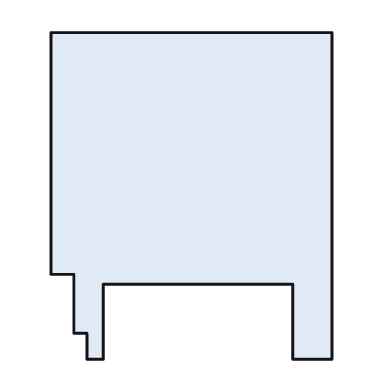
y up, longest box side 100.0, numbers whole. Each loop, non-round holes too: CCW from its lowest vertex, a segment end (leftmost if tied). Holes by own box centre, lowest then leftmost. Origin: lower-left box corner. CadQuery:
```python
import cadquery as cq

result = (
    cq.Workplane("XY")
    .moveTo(11.0, 0.0)
    .lineTo(16.0, 0.0)
    .lineTo(16.0, 23.0)
    .lineTo(74.0, 23.0)
    .lineTo(74.0, 0.0)
    .lineTo(86.0, 0.0)
    .lineTo(86.0, 100.0)
    .lineTo(0.0, 100.0)
    .lineTo(0.0, 26.0)
    .lineTo(7.0, 26.0)
    .lineTo(7.0, 8.0)
    .lineTo(11.0, 8.0)
    .close()
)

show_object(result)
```